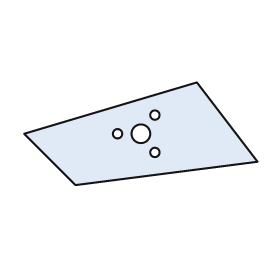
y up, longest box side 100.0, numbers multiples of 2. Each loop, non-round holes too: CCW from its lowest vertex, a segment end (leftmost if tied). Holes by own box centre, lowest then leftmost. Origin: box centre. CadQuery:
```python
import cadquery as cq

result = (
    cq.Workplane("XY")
    .moveTo(-28.0, -22.0)
    .lineTo(50.0, -12.0)
    .lineTo(24.0, 22.0)
    .lineTo(-50.0, 0.0)
    .close()
    .moveTo(6.0, -8.0)
    .circle(2.0)
    .moveTo(-10.0, 0.0)
    .circle(2.0)
    .moveTo(0.0, 0.0)
    .circle(4.0)
    .moveTo(6.0, 8.0)
    .circle(2.0)
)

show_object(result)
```